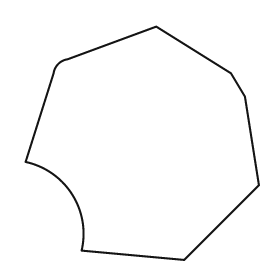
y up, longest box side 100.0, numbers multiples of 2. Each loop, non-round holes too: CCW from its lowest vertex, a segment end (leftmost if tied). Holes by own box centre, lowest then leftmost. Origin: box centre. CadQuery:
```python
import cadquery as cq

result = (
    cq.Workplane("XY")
    .moveTo(18.0, -50.0)
    .lineTo(50.0, -18.0)
    .lineTo(44.0, 20.0)
    .lineTo(38.0, 30.0)
    .lineTo(6.0, 50.0)
    .lineTo(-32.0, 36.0)
    .threePointArc((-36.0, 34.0), (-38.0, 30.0))
    .lineTo(-50.0, -8.0)
    .threePointArc((-30.0, -22.0), (-26.0, -46.0))
    .close()
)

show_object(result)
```